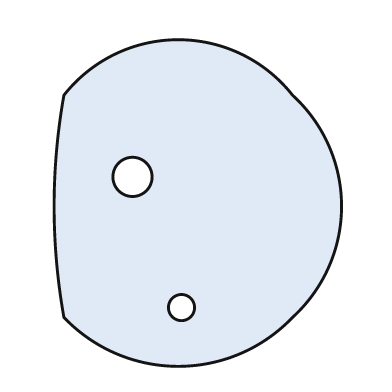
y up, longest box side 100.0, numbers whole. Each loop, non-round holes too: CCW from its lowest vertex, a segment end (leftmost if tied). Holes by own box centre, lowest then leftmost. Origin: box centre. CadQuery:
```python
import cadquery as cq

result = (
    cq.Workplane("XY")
    .moveTo(-41.0, -35.0)
    .threePointArc((-6.0, -50.0), (29.0, -35.0))
    .threePointArc((44.0, -1.0), (29.0, 33.0))
    .threePointArc((-6.0, 50.0), (-41.0, 33.0))
    .threePointArc((-44.0, -1.0), (-41.0, -35.0))
    .close()
    .moveTo(-5.0, -32.0)
    .circle(4.0)
    .moveTo(-20.0, 8.0)
    .circle(6.0)
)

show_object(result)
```